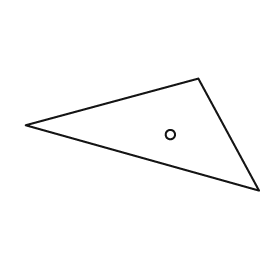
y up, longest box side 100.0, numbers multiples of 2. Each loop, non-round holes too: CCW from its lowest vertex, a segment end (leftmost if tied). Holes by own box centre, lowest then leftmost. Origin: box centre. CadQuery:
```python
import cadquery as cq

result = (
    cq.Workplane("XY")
    .moveTo(50.0, -24.0)
    .lineTo(24.0, 24.0)
    .lineTo(-50.0, 4.0)
    .close()
    .moveTo(12.0, 0.0)
    .circle(2.0)
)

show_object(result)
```